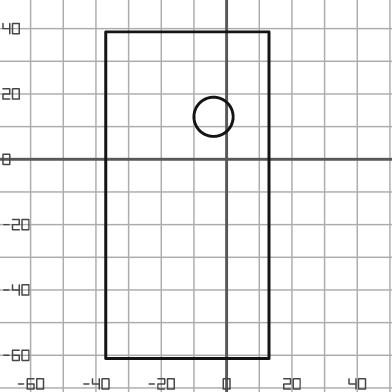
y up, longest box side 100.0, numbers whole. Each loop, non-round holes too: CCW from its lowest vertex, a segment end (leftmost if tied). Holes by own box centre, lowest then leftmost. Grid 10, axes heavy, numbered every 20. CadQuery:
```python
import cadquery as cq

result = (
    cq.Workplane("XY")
    .moveTo(-37.0, -61.0)
    .lineTo(13.0, -61.0)
    .lineTo(13.0, 39.0)
    .lineTo(-37.0, 39.0)
    .close()
    .moveTo(-4.0, 13.0)
    .circle(6.0)
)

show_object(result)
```